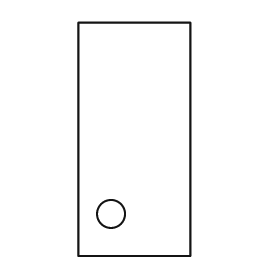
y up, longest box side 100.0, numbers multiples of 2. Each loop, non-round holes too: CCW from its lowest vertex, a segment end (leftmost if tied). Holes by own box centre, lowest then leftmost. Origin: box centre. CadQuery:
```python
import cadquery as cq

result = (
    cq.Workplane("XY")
    .moveTo(-24.0, -50.0)
    .lineTo(24.0, -50.0)
    .lineTo(24.0, 50.0)
    .lineTo(-24.0, 50.0)
    .close()
    .moveTo(-10.0, -32.0)
    .circle(6.0)
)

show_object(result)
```